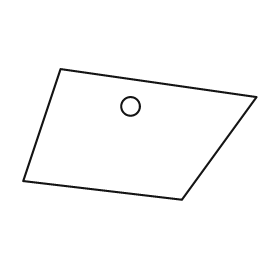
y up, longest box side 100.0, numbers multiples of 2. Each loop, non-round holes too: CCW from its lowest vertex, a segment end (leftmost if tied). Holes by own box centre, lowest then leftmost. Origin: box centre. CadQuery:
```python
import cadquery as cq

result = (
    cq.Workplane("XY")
    .moveTo(18.0, -28.0)
    .lineTo(50.0, 16.0)
    .lineTo(-34.0, 28.0)
    .lineTo(-50.0, -20.0)
    .close()
    .moveTo(-4.0, 12.0)
    .circle(4.0)
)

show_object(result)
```